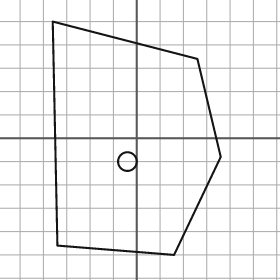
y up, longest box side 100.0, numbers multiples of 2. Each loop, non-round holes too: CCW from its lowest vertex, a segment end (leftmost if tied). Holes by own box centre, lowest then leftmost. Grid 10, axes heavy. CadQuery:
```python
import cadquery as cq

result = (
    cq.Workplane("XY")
    .moveTo(16.0, -50.0)
    .lineTo(36.0, -8.0)
    .lineTo(26.0, 34.0)
    .lineTo(-36.0, 50.0)
    .lineTo(-34.0, -46.0)
    .close()
    .moveTo(-4.0, -10.0)
    .circle(4.0)
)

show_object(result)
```